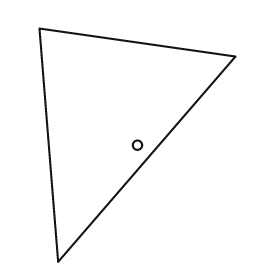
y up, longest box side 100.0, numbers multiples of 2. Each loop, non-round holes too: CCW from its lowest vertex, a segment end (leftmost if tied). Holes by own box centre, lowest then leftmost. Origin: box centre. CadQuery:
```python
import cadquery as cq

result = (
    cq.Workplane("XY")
    .moveTo(-34.0, -50.0)
    .lineTo(42.0, 38.0)
    .lineTo(-42.0, 50.0)
    .close()
    .moveTo(0.0, 0.0)
    .circle(2.0)
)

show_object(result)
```